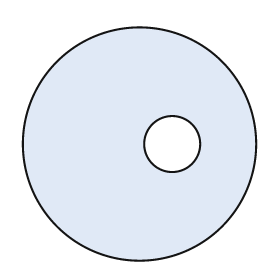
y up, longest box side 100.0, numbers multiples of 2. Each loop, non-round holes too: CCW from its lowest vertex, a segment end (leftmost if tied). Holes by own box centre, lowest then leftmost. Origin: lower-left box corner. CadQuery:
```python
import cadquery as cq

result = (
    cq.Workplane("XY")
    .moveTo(50.0, 50.0)
    .circle(50.0)
    .moveTo(64.0, 50.0)
    .circle(12.0)
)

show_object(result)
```